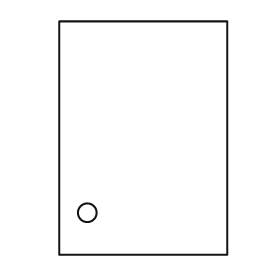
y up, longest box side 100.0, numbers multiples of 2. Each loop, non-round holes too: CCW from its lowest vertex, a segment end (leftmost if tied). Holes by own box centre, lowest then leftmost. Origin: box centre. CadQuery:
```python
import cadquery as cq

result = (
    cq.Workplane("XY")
    .moveTo(-36.0, -50.0)
    .lineTo(36.0, -50.0)
    .lineTo(36.0, 50.0)
    .lineTo(-36.0, 50.0)
    .close()
    .moveTo(-24.0, -32.0)
    .circle(4.0)
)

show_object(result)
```